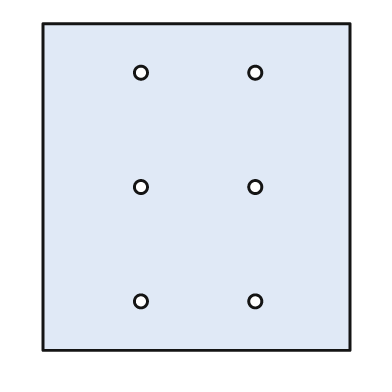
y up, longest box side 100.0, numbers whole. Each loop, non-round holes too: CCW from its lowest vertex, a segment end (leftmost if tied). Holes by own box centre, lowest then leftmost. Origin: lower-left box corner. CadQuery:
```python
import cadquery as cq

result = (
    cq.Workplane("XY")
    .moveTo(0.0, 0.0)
    .lineTo(94.0, 0.0)
    .lineTo(94.0, 100.0)
    .lineTo(0.0, 100.0)
    .close()
    .moveTo(30.0, 15.0)
    .circle(2.0)
    .moveTo(65.0, 15.0)
    .circle(2.0)
    .moveTo(30.0, 50.0)
    .circle(2.0)
    .moveTo(65.0, 50.0)
    .circle(2.0)
    .moveTo(30.0, 85.0)
    .circle(2.0)
    .moveTo(65.0, 85.0)
    .circle(2.0)
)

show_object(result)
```